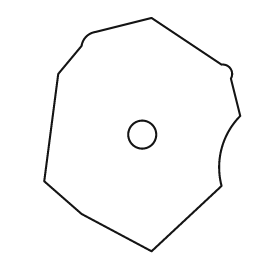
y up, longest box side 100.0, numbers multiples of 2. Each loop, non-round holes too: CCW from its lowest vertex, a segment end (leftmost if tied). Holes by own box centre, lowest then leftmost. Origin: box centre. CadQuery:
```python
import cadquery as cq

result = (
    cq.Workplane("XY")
    .moveTo(4.0, -50.0)
    .lineTo(34.0, -22.0)
    .threePointArc((34.0, -6.0), (42.0, 8.0))
    .lineTo(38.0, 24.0)
    .threePointArc((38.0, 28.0), (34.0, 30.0))
    .lineTo(4.0, 50.0)
    .lineTo(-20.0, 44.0)
    .threePointArc((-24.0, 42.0), (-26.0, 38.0))
    .lineTo(-36.0, 26.0)
    .lineTo(-42.0, -20.0)
    .lineTo(-26.0, -34.0)
    .close()
    .moveTo(0.0, 0.0)
    .circle(6.0)
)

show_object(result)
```